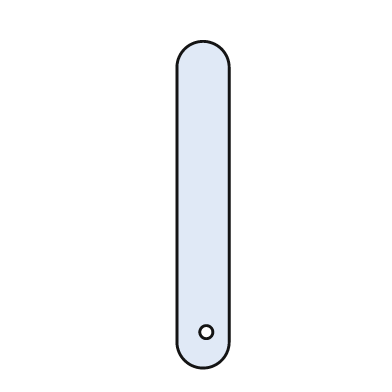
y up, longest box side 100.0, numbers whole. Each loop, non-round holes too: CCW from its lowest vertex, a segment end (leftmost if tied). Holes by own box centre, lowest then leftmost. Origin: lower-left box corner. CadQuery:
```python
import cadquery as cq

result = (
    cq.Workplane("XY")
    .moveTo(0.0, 8.0)
    .threePointArc((8.0, 0.0), (16.0, 8.0))
    .lineTo(16.0, 92.0)
    .threePointArc((8.0, 100.0), (0.0, 92.0))
    .close()
    .moveTo(9.0, 11.0)
    .circle(2.0)
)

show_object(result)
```